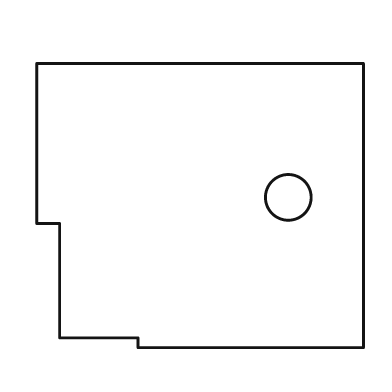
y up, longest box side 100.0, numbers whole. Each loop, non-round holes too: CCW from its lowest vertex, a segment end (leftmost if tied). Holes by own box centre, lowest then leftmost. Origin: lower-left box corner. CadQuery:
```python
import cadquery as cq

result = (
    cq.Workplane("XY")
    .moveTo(31.0, 0.0)
    .lineTo(100.0, 0.0)
    .lineTo(100.0, 87.0)
    .lineTo(0.0, 87.0)
    .lineTo(0.0, 38.0)
    .lineTo(7.0, 38.0)
    .lineTo(7.0, 3.0)
    .lineTo(31.0, 3.0)
    .close()
    .moveTo(77.0, 46.0)
    .circle(7.0)
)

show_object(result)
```